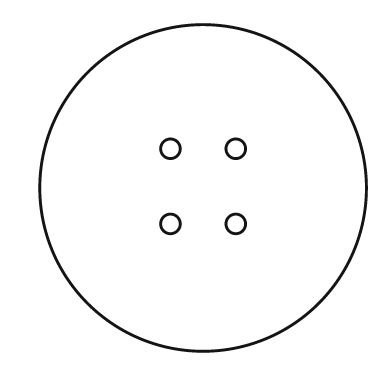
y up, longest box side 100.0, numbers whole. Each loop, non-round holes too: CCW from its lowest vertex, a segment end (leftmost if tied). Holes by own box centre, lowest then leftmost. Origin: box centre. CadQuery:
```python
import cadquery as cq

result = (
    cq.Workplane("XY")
    .moveTo(0.0, 0.0)
    .circle(50.0)
    .moveTo(-10.0, -11.0)
    .circle(3.0)
    .moveTo(10.0, -11.0)
    .circle(3.0)
    .moveTo(-10.0, 12.0)
    .circle(3.0)
    .moveTo(10.0, 12.0)
    .circle(3.0)
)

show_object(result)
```